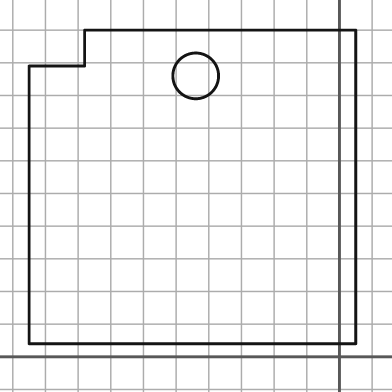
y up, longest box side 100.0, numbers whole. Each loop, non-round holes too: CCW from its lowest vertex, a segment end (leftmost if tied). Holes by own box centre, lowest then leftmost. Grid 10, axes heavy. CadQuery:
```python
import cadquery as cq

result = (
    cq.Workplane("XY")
    .moveTo(-95.0, 4.0)
    .lineTo(5.0, 4.0)
    .lineTo(5.0, 100.0)
    .lineTo(-78.0, 100.0)
    .lineTo(-78.0, 89.0)
    .lineTo(-95.0, 89.0)
    .close()
    .moveTo(-44.0, 86.0)
    .circle(7.0)
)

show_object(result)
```